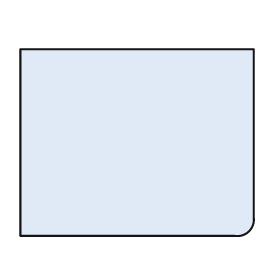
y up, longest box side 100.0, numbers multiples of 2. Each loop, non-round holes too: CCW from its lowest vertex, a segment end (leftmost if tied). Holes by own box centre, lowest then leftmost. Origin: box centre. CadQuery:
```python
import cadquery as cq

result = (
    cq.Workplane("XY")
    .moveTo(-50.0, -40.0)
    .lineTo(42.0, -40.0)
    .threePointArc((48.0, -38.0), (50.0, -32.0))
    .lineTo(50.0, 40.0)
    .lineTo(-50.0, 40.0)
    .close()
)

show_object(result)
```